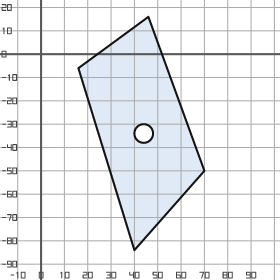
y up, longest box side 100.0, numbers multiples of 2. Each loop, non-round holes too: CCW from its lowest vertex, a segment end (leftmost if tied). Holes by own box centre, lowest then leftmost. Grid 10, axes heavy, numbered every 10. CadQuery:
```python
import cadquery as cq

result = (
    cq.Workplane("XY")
    .moveTo(40.0, -84.0)
    .lineTo(70.0, -50.0)
    .lineTo(46.0, 16.0)
    .lineTo(16.0, -6.0)
    .close()
    .moveTo(44.0, -34.0)
    .circle(4.0)
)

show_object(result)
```